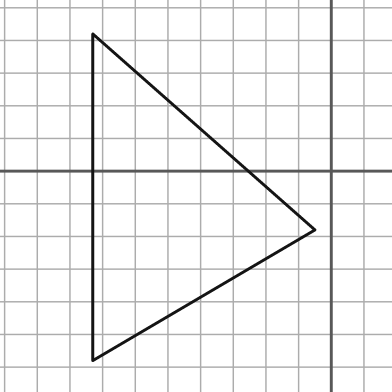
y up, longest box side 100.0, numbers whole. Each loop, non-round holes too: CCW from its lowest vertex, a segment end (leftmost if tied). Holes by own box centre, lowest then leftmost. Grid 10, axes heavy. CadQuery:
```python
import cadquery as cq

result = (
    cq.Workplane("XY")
    .moveTo(-73.0, -58.0)
    .lineTo(-5.0, -18.0)
    .lineTo(-73.0, 42.0)
    .close()
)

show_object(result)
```